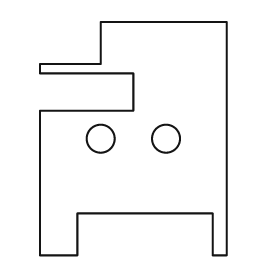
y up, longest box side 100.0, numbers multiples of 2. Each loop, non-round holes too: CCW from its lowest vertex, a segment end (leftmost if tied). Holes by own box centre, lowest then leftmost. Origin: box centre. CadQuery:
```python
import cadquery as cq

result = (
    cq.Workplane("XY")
    .moveTo(-40.0, -50.0)
    .lineTo(-24.0, -50.0)
    .lineTo(-24.0, -32.0)
    .lineTo(34.0, -32.0)
    .lineTo(34.0, -50.0)
    .lineTo(40.0, -50.0)
    .lineTo(40.0, 50.0)
    .lineTo(-14.0, 50.0)
    .lineTo(-14.0, 32.0)
    .lineTo(-40.0, 32.0)
    .lineTo(-40.0, 28.0)
    .lineTo(0.0, 28.0)
    .lineTo(0.0, 12.0)
    .lineTo(-40.0, 12.0)
    .close()
    .moveTo(-14.0, 0.0)
    .circle(6.0)
    .moveTo(14.0, 0.0)
    .circle(6.0)
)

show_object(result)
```